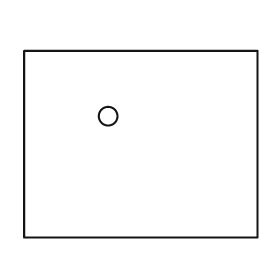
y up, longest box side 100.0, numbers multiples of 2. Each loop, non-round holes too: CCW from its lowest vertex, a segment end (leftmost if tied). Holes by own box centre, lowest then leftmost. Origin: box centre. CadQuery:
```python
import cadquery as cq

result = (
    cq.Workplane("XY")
    .moveTo(-50.0, -40.0)
    .lineTo(50.0, -40.0)
    .lineTo(50.0, 40.0)
    .lineTo(-50.0, 40.0)
    .close()
    .moveTo(-14.0, 12.0)
    .circle(4.0)
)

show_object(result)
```